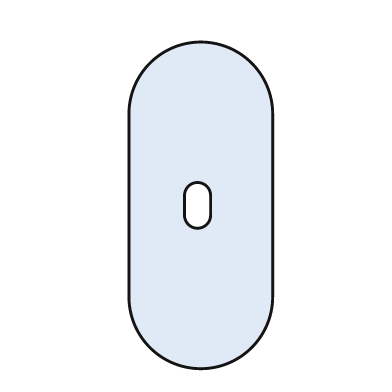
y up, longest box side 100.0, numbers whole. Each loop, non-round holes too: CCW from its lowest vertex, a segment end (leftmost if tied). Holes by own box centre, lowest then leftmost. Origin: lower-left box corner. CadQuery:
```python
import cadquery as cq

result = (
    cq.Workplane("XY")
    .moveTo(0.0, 22.0)
    .threePointArc((22.0, 0.0), (44.0, 22.0))
    .lineTo(44.0, 78.0)
    .threePointArc((22.0, 100.0), (0.0, 78.0))
    .close()
    .moveTo(17.0, 47.0)
    .threePointArc((21.0, 43.0), (25.0, 47.0))
    .lineTo(25.0, 53.0)
    .threePointArc((21.0, 57.0), (17.0, 53.0))
    .close()
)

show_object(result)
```